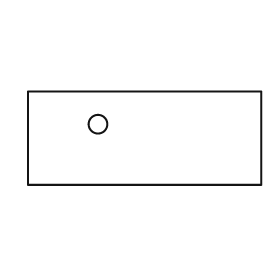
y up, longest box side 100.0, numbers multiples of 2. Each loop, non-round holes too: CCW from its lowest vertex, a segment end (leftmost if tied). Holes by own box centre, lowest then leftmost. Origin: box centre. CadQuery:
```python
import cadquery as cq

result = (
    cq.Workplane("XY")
    .moveTo(-50.0, -20.0)
    .lineTo(50.0, -20.0)
    .lineTo(50.0, 20.0)
    .lineTo(-50.0, 20.0)
    .close()
    .moveTo(-20.0, 6.0)
    .circle(4.0)
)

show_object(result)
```